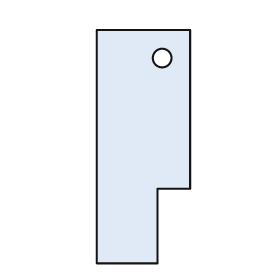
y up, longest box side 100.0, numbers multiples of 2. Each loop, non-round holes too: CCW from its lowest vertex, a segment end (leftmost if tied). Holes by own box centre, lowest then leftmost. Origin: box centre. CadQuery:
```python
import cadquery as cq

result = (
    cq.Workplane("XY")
    .moveTo(-20.0, -50.0)
    .lineTo(6.0, -50.0)
    .lineTo(6.0, -18.0)
    .lineTo(20.0, -18.0)
    .lineTo(20.0, 50.0)
    .lineTo(-20.0, 50.0)
    .close()
    .moveTo(8.0, 38.0)
    .circle(4.0)
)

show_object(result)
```